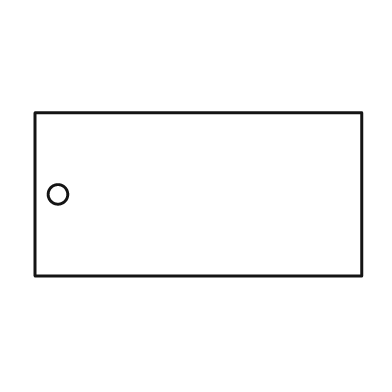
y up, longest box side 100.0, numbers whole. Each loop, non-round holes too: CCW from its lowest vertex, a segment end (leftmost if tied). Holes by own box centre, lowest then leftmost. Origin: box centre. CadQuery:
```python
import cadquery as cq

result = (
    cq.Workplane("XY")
    .moveTo(-50.0, -25.0)
    .lineTo(50.0, -25.0)
    .lineTo(50.0, 25.0)
    .lineTo(-50.0, 25.0)
    .close()
    .moveTo(-43.0, 0.0)
    .circle(3.0)
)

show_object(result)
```